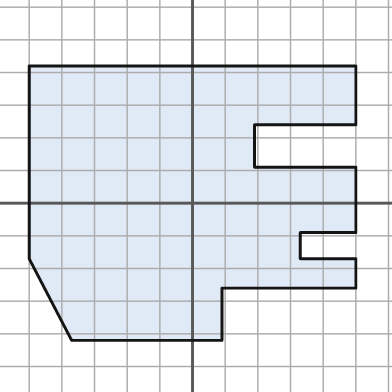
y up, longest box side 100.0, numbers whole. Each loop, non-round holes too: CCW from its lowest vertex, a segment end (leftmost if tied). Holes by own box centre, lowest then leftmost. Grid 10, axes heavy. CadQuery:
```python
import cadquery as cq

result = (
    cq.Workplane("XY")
    .moveTo(-37.0, -42.0)
    .lineTo(9.0, -42.0)
    .lineTo(9.0, -26.0)
    .lineTo(50.0, -26.0)
    .lineTo(50.0, -17.0)
    .lineTo(33.0, -17.0)
    .lineTo(33.0, -9.0)
    .lineTo(50.0, -9.0)
    .lineTo(50.0, 11.0)
    .lineTo(19.0, 11.0)
    .lineTo(19.0, 24.0)
    .lineTo(50.0, 24.0)
    .lineTo(50.0, 42.0)
    .lineTo(-50.0, 42.0)
    .lineTo(-50.0, -17.0)
    .close()
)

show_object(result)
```